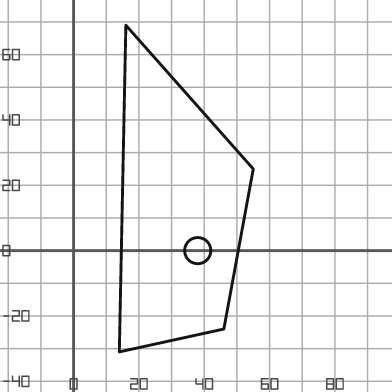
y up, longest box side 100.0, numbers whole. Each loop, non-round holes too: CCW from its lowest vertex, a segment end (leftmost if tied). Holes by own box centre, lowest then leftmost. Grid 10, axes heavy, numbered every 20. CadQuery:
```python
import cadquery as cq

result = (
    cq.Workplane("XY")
    .moveTo(14.0, -31.0)
    .lineTo(46.0, -24.0)
    .lineTo(55.0, 25.0)
    .lineTo(16.0, 69.0)
    .close()
    .moveTo(38.0, 0.0)
    .circle(4.0)
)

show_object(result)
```